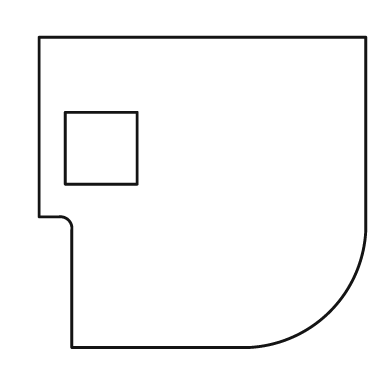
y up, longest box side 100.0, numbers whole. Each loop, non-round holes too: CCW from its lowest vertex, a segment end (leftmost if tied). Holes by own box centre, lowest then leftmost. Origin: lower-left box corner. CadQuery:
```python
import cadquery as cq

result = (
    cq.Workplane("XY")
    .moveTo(10.0, 0.0)
    .lineTo(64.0, 0.0)
    .threePointArc((89.0, 11.0), (100.0, 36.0))
    .lineTo(100.0, 95.0)
    .lineTo(0.0, 95.0)
    .lineTo(0.0, 40.0)
    .lineTo(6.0, 40.0)
    .threePointArc((9.0, 39.0), (10.0, 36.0))
    .close()
    .moveTo(8.0, 50.0)
    .lineTo(30.0, 50.0)
    .lineTo(30.0, 72.0)
    .lineTo(8.0, 72.0)
    .close()
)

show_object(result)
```